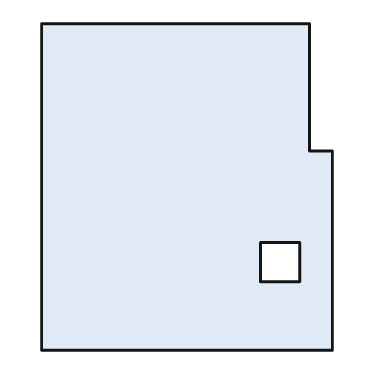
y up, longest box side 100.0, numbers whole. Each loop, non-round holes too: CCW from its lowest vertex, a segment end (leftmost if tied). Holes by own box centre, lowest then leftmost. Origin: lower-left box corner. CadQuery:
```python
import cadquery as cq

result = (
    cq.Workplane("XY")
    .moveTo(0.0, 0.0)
    .lineTo(89.0, 0.0)
    .lineTo(89.0, 61.0)
    .lineTo(82.0, 61.0)
    .lineTo(82.0, 100.0)
    .lineTo(0.0, 100.0)
    .close()
    .moveTo(67.0, 21.0)
    .lineTo(79.0, 21.0)
    .lineTo(79.0, 33.0)
    .lineTo(67.0, 33.0)
    .close()
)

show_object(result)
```